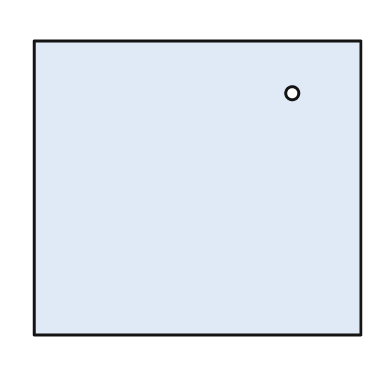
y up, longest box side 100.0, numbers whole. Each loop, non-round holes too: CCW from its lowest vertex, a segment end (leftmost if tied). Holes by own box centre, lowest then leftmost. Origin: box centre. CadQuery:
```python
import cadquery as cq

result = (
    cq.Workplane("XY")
    .moveTo(-50.0, -45.0)
    .lineTo(50.0, -45.0)
    .lineTo(50.0, 45.0)
    .lineTo(-50.0, 45.0)
    .close()
    .moveTo(29.0, 29.0)
    .circle(2.0)
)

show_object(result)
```